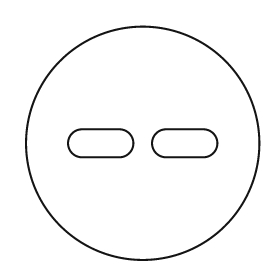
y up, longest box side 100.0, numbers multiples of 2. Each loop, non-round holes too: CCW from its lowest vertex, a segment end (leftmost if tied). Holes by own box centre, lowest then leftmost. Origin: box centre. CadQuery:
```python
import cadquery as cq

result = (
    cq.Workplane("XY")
    .moveTo(0.0, 0.0)
    .circle(50.0)
    .moveTo(-26.0, -6.0)
    .lineTo(-10.0, -6.0)
    .threePointArc((-4.0, 0.0), (-10.0, 6.0))
    .lineTo(-26.0, 6.0)
    .threePointArc((-32.0, 0.0), (-26.0, -6.0))
    .close()
    .moveTo(10.0, -6.0)
    .lineTo(26.0, -6.0)
    .threePointArc((32.0, 0.0), (26.0, 6.0))
    .lineTo(10.0, 6.0)
    .threePointArc((4.0, 0.0), (10.0, -6.0))
    .close()
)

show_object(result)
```